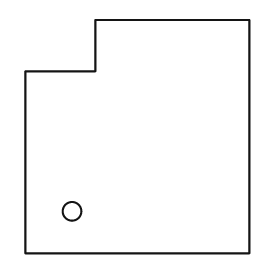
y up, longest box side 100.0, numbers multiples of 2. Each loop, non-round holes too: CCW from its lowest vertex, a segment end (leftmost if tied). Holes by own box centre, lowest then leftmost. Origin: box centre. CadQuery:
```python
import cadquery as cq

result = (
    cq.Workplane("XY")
    .moveTo(-48.0, -50.0)
    .lineTo(48.0, -50.0)
    .lineTo(48.0, 50.0)
    .lineTo(-18.0, 50.0)
    .lineTo(-18.0, 28.0)
    .lineTo(-48.0, 28.0)
    .close()
    .moveTo(-28.0, -32.0)
    .circle(4.0)
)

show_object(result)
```